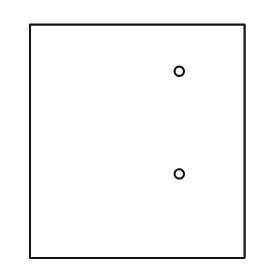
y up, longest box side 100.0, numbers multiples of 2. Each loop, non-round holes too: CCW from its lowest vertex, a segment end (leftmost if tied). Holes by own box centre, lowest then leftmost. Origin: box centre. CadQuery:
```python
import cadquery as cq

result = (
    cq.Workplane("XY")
    .moveTo(-46.0, -50.0)
    .lineTo(46.0, -50.0)
    .lineTo(46.0, 50.0)
    .lineTo(-46.0, 50.0)
    .close()
    .moveTo(18.0, -14.0)
    .circle(2.0)
    .moveTo(18.0, 30.0)
    .circle(2.0)
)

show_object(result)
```